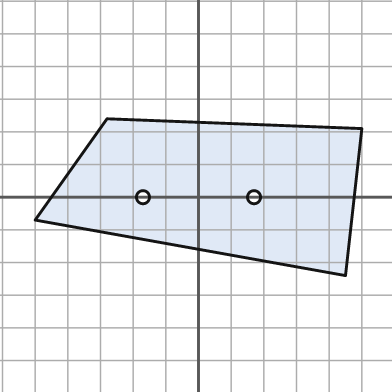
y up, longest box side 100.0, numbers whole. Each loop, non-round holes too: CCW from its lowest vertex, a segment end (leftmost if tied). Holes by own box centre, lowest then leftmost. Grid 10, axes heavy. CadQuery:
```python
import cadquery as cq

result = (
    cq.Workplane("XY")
    .moveTo(45.0, -24.0)
    .lineTo(50.0, 21.0)
    .lineTo(-28.0, 24.0)
    .lineTo(-50.0, -7.0)
    .close()
    .moveTo(-17.0, 0.0)
    .circle(2.0)
    .moveTo(17.0, 0.0)
    .circle(2.0)
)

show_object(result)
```